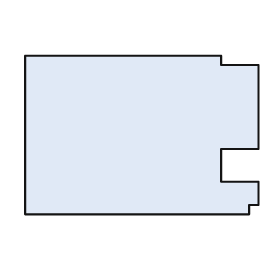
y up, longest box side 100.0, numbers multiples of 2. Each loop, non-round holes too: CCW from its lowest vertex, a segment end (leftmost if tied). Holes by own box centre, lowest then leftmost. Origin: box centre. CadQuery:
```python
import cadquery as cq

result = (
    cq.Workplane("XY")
    .moveTo(-50.0, -34.0)
    .lineTo(46.0, -34.0)
    .lineTo(46.0, -30.0)
    .lineTo(50.0, -30.0)
    .lineTo(50.0, -20.0)
    .lineTo(34.0, -20.0)
    .lineTo(34.0, -6.0)
    .lineTo(50.0, -6.0)
    .lineTo(50.0, 30.0)
    .lineTo(34.0, 30.0)
    .lineTo(34.0, 34.0)
    .lineTo(-50.0, 34.0)
    .close()
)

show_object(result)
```